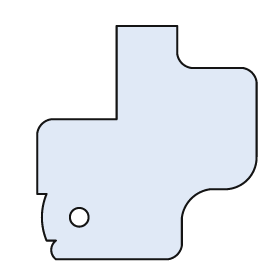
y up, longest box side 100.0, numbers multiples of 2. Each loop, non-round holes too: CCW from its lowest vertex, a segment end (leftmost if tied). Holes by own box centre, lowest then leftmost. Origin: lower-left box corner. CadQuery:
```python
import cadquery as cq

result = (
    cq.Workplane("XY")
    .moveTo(8.0, 0.0)
    .lineTo(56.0, 0.0)
    .threePointArc((60.0, 2.0), (62.0, 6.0))
    .lineTo(62.0, 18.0)
    .threePointArc((66.0, 26.0), (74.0, 30.0))
    .lineTo(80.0, 30.0)
    .threePointArc((90.0, 34.0), (94.0, 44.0))
    .lineTo(94.0, 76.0)
    .threePointArc((92.0, 80.0), (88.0, 82.0))
    .lineTo(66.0, 82.0)
    .threePointArc((62.0, 84.0), (60.0, 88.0))
    .lineTo(60.0, 100.0)
    .lineTo(34.0, 100.0)
    .lineTo(34.0, 60.0)
    .lineTo(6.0, 60.0)
    .threePointArc((2.0, 58.0), (0.0, 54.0))
    .lineTo(0.0, 28.0)
    .lineTo(4.0, 28.0)
    .threePointArc((2.0, 18.0), (4.0, 8.0))
    .lineTo(8.0, 8.0)
    .threePointArc((6.0, 4.0), (8.0, 0.0))
    .close()
    .moveTo(18.0, 18.0)
    .circle(4.0)
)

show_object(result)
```